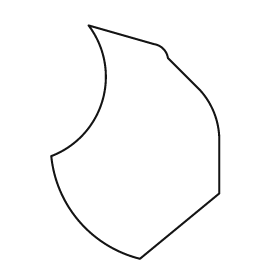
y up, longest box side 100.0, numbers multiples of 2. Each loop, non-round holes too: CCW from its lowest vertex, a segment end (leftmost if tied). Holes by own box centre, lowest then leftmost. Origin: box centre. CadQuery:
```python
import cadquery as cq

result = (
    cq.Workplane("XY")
    .moveTo(2.0, -50.0)
    .lineTo(36.0, -22.0)
    .lineTo(36.0, 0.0)
    .threePointArc((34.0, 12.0), (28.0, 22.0))
    .lineTo(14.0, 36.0)
    .threePointArc((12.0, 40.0), (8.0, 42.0))
    .lineTo(-20.0, 50.0)
    .threePointArc((-14.0, 18.0), (-36.0, -6.0))
    .threePointArc((-24.0, -34.0), (2.0, -50.0))
    .close()
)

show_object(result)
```